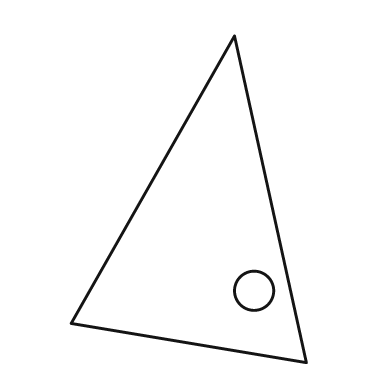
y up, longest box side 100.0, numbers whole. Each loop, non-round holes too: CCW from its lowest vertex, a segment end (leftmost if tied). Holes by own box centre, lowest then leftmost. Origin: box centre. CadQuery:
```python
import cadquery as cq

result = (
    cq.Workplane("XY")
    .moveTo(36.0, -50.0)
    .lineTo(14.0, 50.0)
    .lineTo(-36.0, -38.0)
    .close()
    .moveTo(20.0, -28.0)
    .circle(6.0)
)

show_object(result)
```